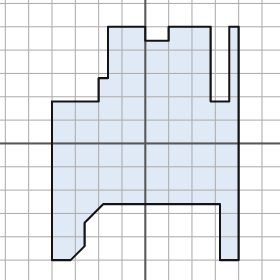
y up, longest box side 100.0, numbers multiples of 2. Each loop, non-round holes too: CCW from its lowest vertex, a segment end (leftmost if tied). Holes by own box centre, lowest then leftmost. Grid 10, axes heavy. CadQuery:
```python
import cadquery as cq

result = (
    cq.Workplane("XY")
    .moveTo(-40.0, -50.0)
    .lineTo(-32.0, -50.0)
    .lineTo(-26.0, -44.0)
    .lineTo(-26.0, -34.0)
    .lineTo(-18.0, -26.0)
    .lineTo(32.0, -26.0)
    .lineTo(32.0, -50.0)
    .lineTo(40.0, -50.0)
    .lineTo(40.0, 50.0)
    .lineTo(36.0, 50.0)
    .lineTo(36.0, 18.0)
    .lineTo(28.0, 18.0)
    .lineTo(28.0, 50.0)
    .lineTo(10.0, 50.0)
    .lineTo(10.0, 44.0)
    .lineTo(0.0, 44.0)
    .lineTo(0.0, 50.0)
    .lineTo(-16.0, 50.0)
    .lineTo(-16.0, 28.0)
    .lineTo(-20.0, 28.0)
    .lineTo(-20.0, 18.0)
    .lineTo(-40.0, 18.0)
    .close()
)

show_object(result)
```